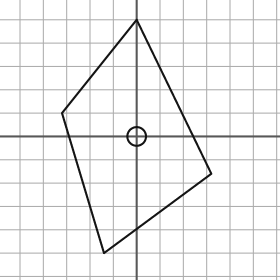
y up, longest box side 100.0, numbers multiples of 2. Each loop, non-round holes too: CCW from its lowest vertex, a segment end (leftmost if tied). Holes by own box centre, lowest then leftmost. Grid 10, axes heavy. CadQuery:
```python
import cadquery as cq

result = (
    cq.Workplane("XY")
    .moveTo(-14.0, -50.0)
    .lineTo(32.0, -16.0)
    .lineTo(0.0, 50.0)
    .lineTo(-32.0, 10.0)
    .close()
    .moveTo(0.0, 0.0)
    .circle(4.0)
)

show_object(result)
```